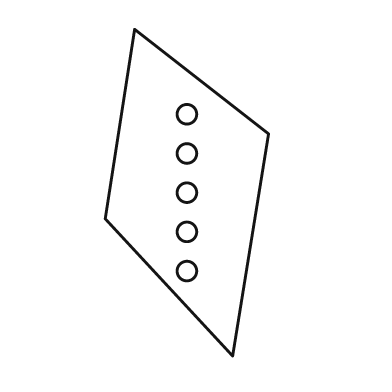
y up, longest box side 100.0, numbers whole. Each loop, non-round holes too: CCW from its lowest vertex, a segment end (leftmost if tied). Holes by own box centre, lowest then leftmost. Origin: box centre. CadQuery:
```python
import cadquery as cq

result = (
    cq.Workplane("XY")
    .moveTo(14.0, -50.0)
    .lineTo(25.0, 18.0)
    .lineTo(-16.0, 50.0)
    .lineTo(-25.0, -8.0)
    .close()
    .moveTo(0.0, -24.0)
    .circle(3.0)
    .moveTo(0.0, -12.0)
    .circle(3.0)
    .moveTo(0.0, 0.0)
    .circle(3.0)
    .moveTo(0.0, 12.0)
    .circle(3.0)
    .moveTo(0.0, 24.0)
    .circle(3.0)
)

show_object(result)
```